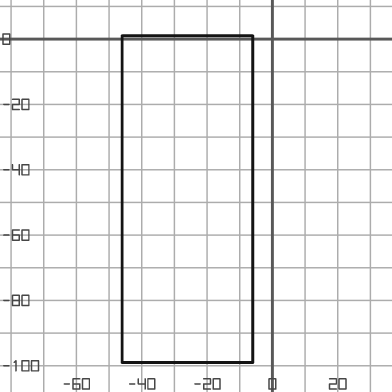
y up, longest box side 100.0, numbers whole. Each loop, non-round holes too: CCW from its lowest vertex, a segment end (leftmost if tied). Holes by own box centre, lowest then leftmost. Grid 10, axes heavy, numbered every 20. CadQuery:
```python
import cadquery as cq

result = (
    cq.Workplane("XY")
    .moveTo(-46.0, -99.0)
    .lineTo(-6.0, -99.0)
    .lineTo(-6.0, 1.0)
    .lineTo(-46.0, 1.0)
    .close()
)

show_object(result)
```